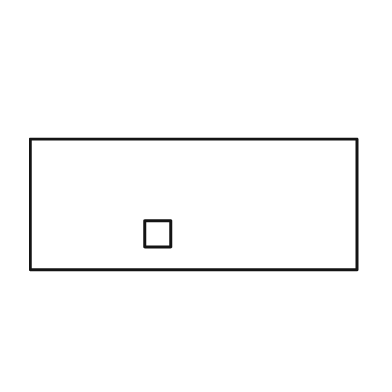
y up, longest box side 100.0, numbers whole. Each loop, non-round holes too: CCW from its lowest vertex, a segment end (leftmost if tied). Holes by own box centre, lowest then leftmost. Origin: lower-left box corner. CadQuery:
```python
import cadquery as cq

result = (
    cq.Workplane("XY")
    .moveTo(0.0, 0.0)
    .lineTo(100.0, 0.0)
    .lineTo(100.0, 40.0)
    .lineTo(0.0, 40.0)
    .close()
    .moveTo(35.0, 7.0)
    .lineTo(43.0, 7.0)
    .lineTo(43.0, 15.0)
    .lineTo(35.0, 15.0)
    .close()
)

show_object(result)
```